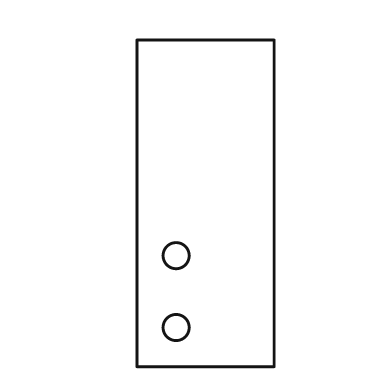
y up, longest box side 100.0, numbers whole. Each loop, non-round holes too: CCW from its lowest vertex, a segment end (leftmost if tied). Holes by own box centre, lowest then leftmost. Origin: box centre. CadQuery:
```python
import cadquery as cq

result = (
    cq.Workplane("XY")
    .moveTo(-21.0, -50.0)
    .lineTo(21.0, -50.0)
    .lineTo(21.0, 50.0)
    .lineTo(-21.0, 50.0)
    .close()
    .moveTo(-9.0, -38.0)
    .circle(4.0)
    .moveTo(-9.0, -16.0)
    .circle(4.0)
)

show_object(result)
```